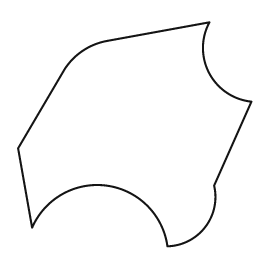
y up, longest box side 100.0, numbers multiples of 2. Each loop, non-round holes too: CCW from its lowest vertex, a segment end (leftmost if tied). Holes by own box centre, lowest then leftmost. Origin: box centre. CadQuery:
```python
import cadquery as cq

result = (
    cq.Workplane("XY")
    .moveTo(14.0, -48.0)
    .threePointArc((30.0, -40.0), (34.0, -22.0))
    .lineTo(50.0, 14.0)
    .threePointArc((32.0, 26.0), (32.0, 48.0))
    .lineTo(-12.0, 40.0)
    .threePointArc((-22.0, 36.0), (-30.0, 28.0))
    .lineTo(-50.0, -6.0)
    .lineTo(-44.0, -40.0)
    .threePointArc((-12.0, -22.0), (14.0, -48.0))
    .close()
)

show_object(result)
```